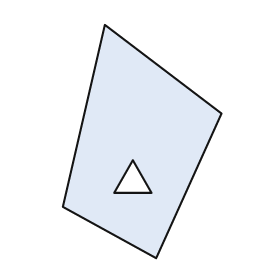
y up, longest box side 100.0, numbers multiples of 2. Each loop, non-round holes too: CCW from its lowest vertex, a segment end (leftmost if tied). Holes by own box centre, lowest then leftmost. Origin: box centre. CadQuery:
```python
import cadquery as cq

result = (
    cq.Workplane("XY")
    .moveTo(6.0, -50.0)
    .lineTo(34.0, 12.0)
    .lineTo(-16.0, 50.0)
    .lineTo(-34.0, -28.0)
    .close()
    .moveTo(-12.0, -22.0)
    .lineTo(4.0, -22.0)
    .lineTo(-4.0, -8.0)
    .close()
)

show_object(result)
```